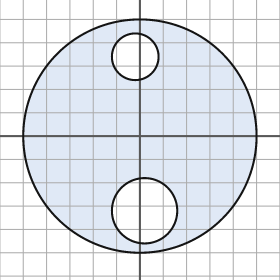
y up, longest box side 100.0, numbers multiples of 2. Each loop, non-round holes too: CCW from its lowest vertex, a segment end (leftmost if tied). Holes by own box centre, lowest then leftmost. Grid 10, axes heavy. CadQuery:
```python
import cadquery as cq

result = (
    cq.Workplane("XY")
    .moveTo(0.0, 0.0)
    .circle(50.0)
    .moveTo(2.0, -32.0)
    .circle(14.0)
    .moveTo(-2.0, 34.0)
    .circle(10.0)
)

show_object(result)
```